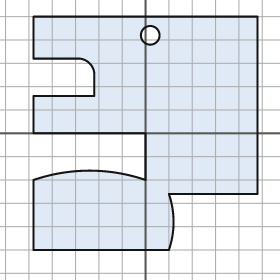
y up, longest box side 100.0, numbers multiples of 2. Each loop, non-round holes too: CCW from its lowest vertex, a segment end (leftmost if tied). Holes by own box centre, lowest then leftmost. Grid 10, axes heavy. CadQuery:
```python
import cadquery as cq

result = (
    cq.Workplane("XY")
    .moveTo(-48.0, -50.0)
    .lineTo(10.0, -50.0)
    .threePointArc((12.0, -38.0), (10.0, -26.0))
    .lineTo(48.0, -26.0)
    .lineTo(48.0, 50.0)
    .lineTo(-48.0, 50.0)
    .lineTo(-48.0, 32.0)
    .lineTo(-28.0, 32.0)
    .threePointArc((-24.0, 30.0), (-22.0, 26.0))
    .lineTo(-22.0, 16.0)
    .lineTo(-48.0, 16.0)
    .lineTo(-48.0, 0.0)
    .lineTo(0.0, 0.0)
    .lineTo(0.0, -20.0)
    .threePointArc((-24.0, -16.0), (-48.0, -20.0))
    .close()
    .moveTo(2.0, 42.0)
    .circle(4.0)
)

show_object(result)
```